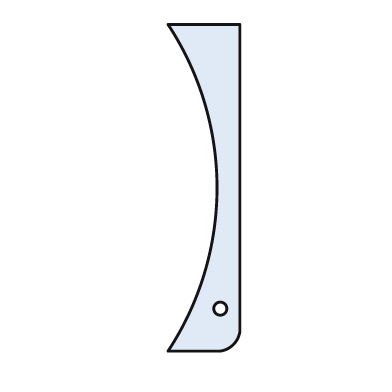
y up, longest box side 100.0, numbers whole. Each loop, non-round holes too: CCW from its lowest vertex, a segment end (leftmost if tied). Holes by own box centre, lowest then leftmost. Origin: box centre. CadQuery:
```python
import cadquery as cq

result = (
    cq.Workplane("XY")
    .moveTo(-11.0, -50.0)
    .lineTo(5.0, -50.0)
    .threePointArc((9.0, -48.0), (11.0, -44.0))
    .lineTo(11.0, 50.0)
    .lineTo(-11.0, 50.0)
    .threePointArc((4.0, 0.0), (-11.0, -50.0))
    .close()
    .moveTo(5.0, -37.0)
    .circle(2.0)
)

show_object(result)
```